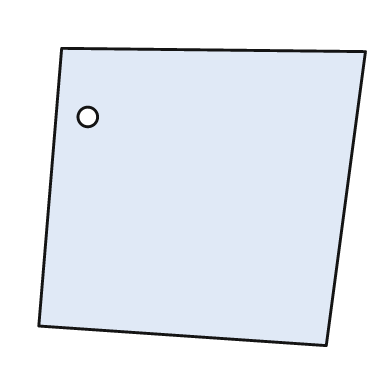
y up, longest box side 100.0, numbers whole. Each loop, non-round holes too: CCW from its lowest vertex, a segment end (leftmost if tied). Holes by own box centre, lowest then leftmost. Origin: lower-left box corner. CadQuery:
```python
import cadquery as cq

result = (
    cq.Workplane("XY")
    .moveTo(88.0, 0.0)
    .lineTo(100.0, 90.0)
    .lineTo(7.0, 91.0)
    .lineTo(0.0, 6.0)
    .close()
    .moveTo(15.0, 70.0)
    .circle(3.0)
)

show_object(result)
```